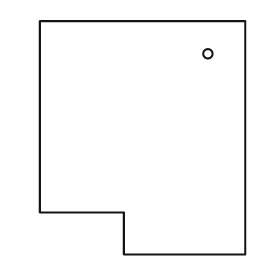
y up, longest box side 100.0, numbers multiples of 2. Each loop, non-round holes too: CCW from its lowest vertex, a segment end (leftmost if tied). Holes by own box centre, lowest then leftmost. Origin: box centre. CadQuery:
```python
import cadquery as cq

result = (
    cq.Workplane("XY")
    .moveTo(-8.0, -50.0)
    .lineTo(44.0, -50.0)
    .lineTo(44.0, 50.0)
    .lineTo(-44.0, 50.0)
    .lineTo(-44.0, -32.0)
    .lineTo(-8.0, -32.0)
    .close()
    .moveTo(28.0, 36.0)
    .circle(2.0)
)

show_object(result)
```